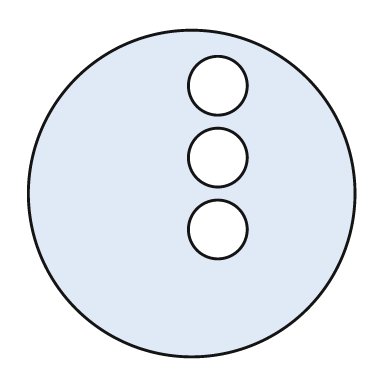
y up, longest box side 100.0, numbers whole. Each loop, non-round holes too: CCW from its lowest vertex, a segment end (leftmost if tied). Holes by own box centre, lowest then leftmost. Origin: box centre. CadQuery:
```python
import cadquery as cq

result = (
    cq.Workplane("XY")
    .moveTo(0.0, 0.0)
    .circle(50.0)
    .moveTo(8.0, -11.0)
    .circle(9.0)
    .moveTo(8.0, 11.0)
    .circle(9.0)
    .moveTo(8.0, 33.0)
    .circle(9.0)
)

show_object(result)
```